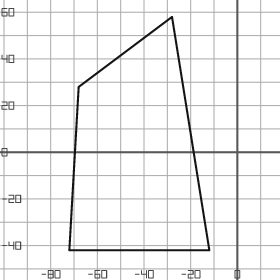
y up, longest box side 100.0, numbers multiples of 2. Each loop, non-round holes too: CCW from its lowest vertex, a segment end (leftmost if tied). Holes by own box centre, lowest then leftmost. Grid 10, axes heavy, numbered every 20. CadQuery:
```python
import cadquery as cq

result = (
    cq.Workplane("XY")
    .moveTo(-72.0, -42.0)
    .lineTo(-12.0, -42.0)
    .lineTo(-28.0, 58.0)
    .lineTo(-68.0, 28.0)
    .close()
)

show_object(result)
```